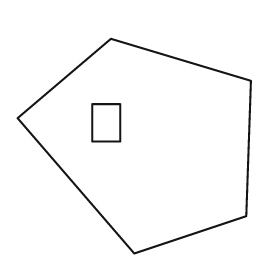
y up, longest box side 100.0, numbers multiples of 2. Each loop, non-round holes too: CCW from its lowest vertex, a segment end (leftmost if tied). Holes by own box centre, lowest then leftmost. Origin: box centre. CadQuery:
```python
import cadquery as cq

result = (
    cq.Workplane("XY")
    .moveTo(0.0, -46.0)
    .lineTo(48.0, -30.0)
    .lineTo(50.0, 28.0)
    .lineTo(-10.0, 46.0)
    .lineTo(-50.0, 12.0)
    .close()
    .moveTo(-18.0, 2.0)
    .lineTo(-6.0, 2.0)
    .lineTo(-6.0, 18.0)
    .lineTo(-18.0, 18.0)
    .close()
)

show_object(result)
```